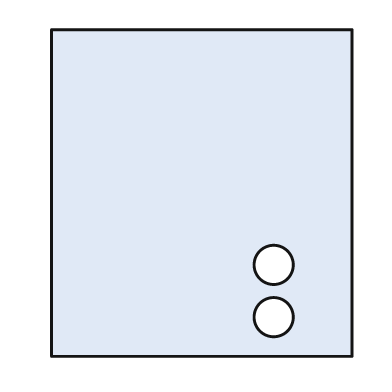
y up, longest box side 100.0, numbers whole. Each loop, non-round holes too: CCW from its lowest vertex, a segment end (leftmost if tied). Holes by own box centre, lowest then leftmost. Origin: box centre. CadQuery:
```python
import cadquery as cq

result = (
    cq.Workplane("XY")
    .moveTo(-46.0, -50.0)
    .lineTo(46.0, -50.0)
    .lineTo(46.0, 50.0)
    .lineTo(-46.0, 50.0)
    .close()
    .moveTo(22.0, -38.0)
    .circle(6.0)
    .moveTo(22.0, -22.0)
    .circle(6.0)
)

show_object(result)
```